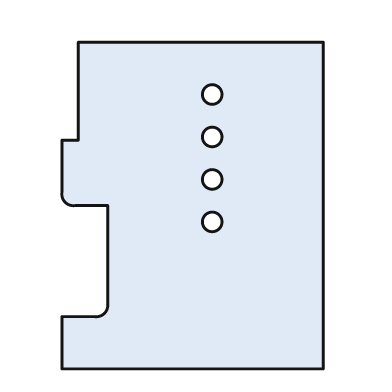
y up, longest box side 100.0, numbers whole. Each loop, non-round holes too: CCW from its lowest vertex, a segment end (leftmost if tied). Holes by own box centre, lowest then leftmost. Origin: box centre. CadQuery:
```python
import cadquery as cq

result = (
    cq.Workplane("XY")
    .moveTo(-40.0, -50.0)
    .lineTo(40.0, -50.0)
    .lineTo(40.0, 50.0)
    .lineTo(-35.0, 50.0)
    .lineTo(-35.0, 20.0)
    .lineTo(-40.0, 20.0)
    .lineTo(-40.0, 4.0)
    .threePointArc((-39.0, 1.0), (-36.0, 0.0))
    .lineTo(-26.0, 0.0)
    .lineTo(-26.0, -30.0)
    .threePointArc((-27.0, -33.0), (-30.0, -34.0))
    .lineTo(-40.0, -34.0)
    .close()
    .moveTo(6.0, -5.0)
    .circle(3.0)
    .moveTo(6.0, 8.0)
    .circle(3.0)
    .moveTo(6.0, 21.0)
    .circle(3.0)
    .moveTo(6.0, 34.0)
    .circle(3.0)
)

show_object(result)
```